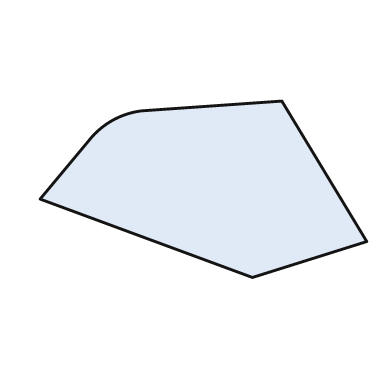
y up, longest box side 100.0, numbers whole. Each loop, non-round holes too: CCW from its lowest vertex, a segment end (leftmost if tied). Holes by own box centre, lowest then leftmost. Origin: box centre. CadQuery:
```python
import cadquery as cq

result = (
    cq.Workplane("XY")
    .moveTo(15.0, -27.0)
    .lineTo(50.0, -16.0)
    .lineTo(24.0, 27.0)
    .lineTo(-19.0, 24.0)
    .threePointArc((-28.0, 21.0), (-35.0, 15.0))
    .lineTo(-50.0, -3.0)
    .close()
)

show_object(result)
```